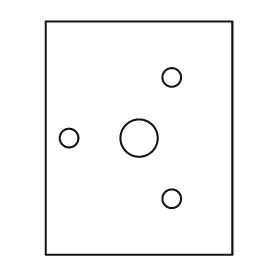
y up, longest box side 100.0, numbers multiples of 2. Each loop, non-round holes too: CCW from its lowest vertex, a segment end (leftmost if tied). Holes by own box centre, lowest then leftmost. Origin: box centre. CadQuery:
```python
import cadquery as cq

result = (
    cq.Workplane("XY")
    .moveTo(-40.0, -50.0)
    .lineTo(40.0, -50.0)
    .lineTo(40.0, 50.0)
    .lineTo(-40.0, 50.0)
    .close()
    .moveTo(14.0, -26.0)
    .circle(4.0)
    .moveTo(-30.0, 0.0)
    .circle(4.0)
    .moveTo(0.0, 0.0)
    .circle(8.0)
    .moveTo(14.0, 26.0)
    .circle(4.0)
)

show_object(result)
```